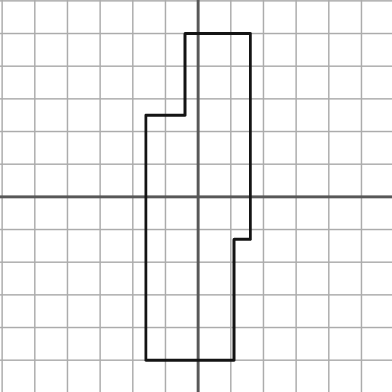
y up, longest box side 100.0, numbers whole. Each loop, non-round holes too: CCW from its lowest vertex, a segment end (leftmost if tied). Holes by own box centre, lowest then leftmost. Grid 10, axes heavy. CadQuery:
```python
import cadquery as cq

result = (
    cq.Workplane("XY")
    .moveTo(-16.0, -50.0)
    .lineTo(11.0, -50.0)
    .lineTo(11.0, -13.0)
    .lineTo(16.0, -13.0)
    .lineTo(16.0, 50.0)
    .lineTo(-4.0, 50.0)
    .lineTo(-4.0, 25.0)
    .lineTo(-16.0, 25.0)
    .close()
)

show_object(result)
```